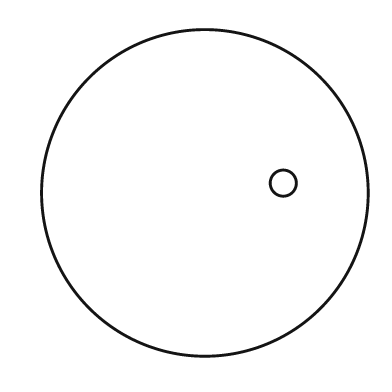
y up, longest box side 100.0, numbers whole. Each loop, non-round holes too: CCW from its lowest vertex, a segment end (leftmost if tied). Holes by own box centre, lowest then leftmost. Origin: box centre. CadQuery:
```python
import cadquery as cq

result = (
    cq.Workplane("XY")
    .moveTo(0.0, 0.0)
    .circle(50.0)
    .moveTo(24.0, 3.0)
    .circle(4.0)
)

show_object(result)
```